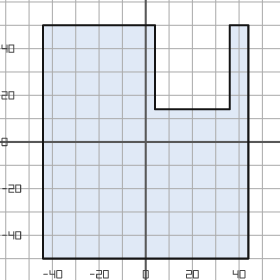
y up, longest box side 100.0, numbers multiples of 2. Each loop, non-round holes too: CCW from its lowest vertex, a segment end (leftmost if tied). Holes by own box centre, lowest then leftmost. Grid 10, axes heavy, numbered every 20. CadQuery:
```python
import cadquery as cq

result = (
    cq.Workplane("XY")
    .moveTo(-44.0, -50.0)
    .lineTo(44.0, -50.0)
    .lineTo(44.0, 50.0)
    .lineTo(36.0, 50.0)
    .lineTo(36.0, 14.0)
    .lineTo(4.0, 14.0)
    .lineTo(4.0, 50.0)
    .lineTo(-44.0, 50.0)
    .close()
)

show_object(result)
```